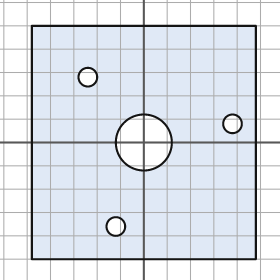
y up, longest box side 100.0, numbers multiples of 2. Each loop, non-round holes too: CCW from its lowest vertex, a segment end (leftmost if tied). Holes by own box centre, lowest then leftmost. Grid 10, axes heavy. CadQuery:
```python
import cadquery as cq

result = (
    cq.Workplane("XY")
    .moveTo(-48.0, -50.0)
    .lineTo(48.0, -50.0)
    .lineTo(48.0, 50.0)
    .lineTo(-48.0, 50.0)
    .close()
    .moveTo(-12.0, -36.0)
    .circle(4.0)
    .moveTo(0.0, 0.0)
    .circle(12.0)
    .moveTo(38.0, 8.0)
    .circle(4.0)
    .moveTo(-24.0, 28.0)
    .circle(4.0)
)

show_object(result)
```